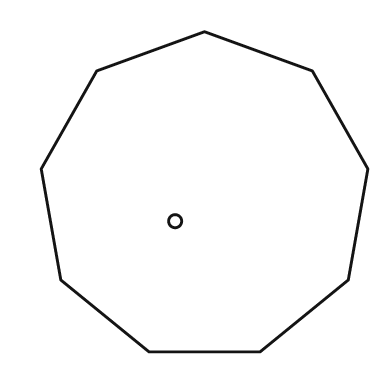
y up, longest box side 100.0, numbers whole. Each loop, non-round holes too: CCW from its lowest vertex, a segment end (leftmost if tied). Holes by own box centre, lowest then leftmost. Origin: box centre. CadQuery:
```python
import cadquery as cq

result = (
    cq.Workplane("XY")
    .moveTo(-17.0, -49.0)
    .lineTo(17.0, -49.0)
    .lineTo(44.0, -27.0)
    .lineTo(50.0, 7.0)
    .lineTo(33.0, 37.0)
    .lineTo(0.0, 49.0)
    .lineTo(-33.0, 37.0)
    .lineTo(-50.0, 7.0)
    .lineTo(-44.0, -27.0)
    .close()
    .moveTo(-9.0, -9.0)
    .circle(2.0)
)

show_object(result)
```